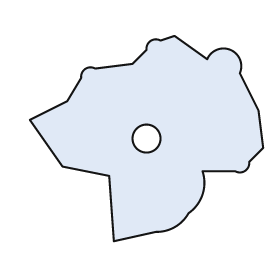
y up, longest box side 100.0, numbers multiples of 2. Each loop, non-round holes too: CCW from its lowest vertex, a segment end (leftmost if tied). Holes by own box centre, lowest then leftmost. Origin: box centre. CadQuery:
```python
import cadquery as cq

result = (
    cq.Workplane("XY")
    .moveTo(-14.0, -44.0)
    .lineTo(4.0, -40.0)
    .threePointArc((12.0, -38.0), (18.0, -32.0))
    .threePointArc((24.0, -24.0), (24.0, -14.0))
    .lineTo(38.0, -14.0)
    .threePointArc((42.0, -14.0), (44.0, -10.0))
    .lineTo(50.0, -4.0)
    .lineTo(48.0, 12.0)
    .lineTo(40.0, 28.0)
    .threePointArc((36.0, 38.0), (26.0, 34.0))
    .lineTo(12.0, 44.0)
    .lineTo(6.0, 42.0)
    .threePointArc((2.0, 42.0), (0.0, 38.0))
    .lineTo(-6.0, 32.0)
    .lineTo(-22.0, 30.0)
    .threePointArc((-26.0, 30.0), (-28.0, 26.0))
    .lineTo(-34.0, 16.0)
    .lineTo(-50.0, 8.0)
    .lineTo(-36.0, -12.0)
    .lineTo(-16.0, -16.0)
    .close()
    .moveTo(0.0, 0.0)
    .circle(6.0)
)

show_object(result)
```